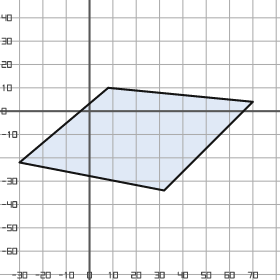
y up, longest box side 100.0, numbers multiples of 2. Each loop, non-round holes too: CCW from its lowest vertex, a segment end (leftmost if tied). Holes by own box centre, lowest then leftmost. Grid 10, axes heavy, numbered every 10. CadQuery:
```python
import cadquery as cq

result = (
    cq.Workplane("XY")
    .moveTo(32.0, -34.0)
    .lineTo(70.0, 4.0)
    .lineTo(8.0, 10.0)
    .lineTo(-30.0, -22.0)
    .close()
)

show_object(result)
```